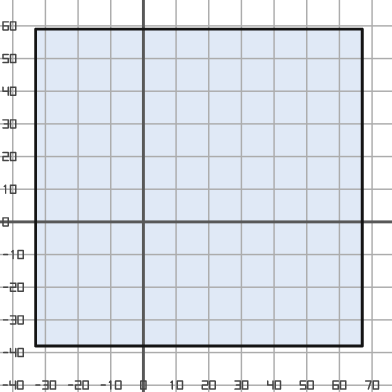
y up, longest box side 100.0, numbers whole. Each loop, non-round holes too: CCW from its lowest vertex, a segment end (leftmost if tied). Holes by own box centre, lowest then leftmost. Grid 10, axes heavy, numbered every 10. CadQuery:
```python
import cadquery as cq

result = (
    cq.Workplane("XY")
    .moveTo(-33.0, -38.0)
    .lineTo(67.0, -38.0)
    .lineTo(67.0, 59.0)
    .lineTo(-33.0, 59.0)
    .close()
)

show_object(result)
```